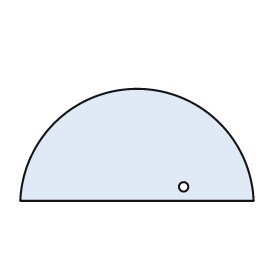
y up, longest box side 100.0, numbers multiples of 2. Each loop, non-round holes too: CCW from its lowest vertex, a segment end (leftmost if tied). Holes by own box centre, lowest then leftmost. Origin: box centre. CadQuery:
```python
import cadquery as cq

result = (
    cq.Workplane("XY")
    .moveTo(-50.0, -24.0)
    .lineTo(50.0, -24.0)
    .threePointArc((0.0, 24.0), (-50.0, -24.0))
    .close()
    .moveTo(20.0, -18.0)
    .circle(2.0)
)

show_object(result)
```